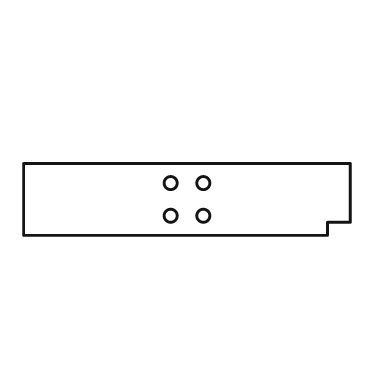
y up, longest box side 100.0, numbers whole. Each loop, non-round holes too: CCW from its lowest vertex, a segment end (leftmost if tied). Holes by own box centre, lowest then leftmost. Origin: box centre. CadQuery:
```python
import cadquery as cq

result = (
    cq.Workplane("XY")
    .moveTo(-50.0, -11.0)
    .lineTo(43.0, -11.0)
    .lineTo(43.0, -7.0)
    .lineTo(50.0, -7.0)
    .lineTo(50.0, 11.0)
    .lineTo(-50.0, 11.0)
    .close()
    .moveTo(-5.0, -5.0)
    .circle(2.0)
    .moveTo(5.0, -5.0)
    .circle(2.0)
    .moveTo(-5.0, 5.0)
    .circle(2.0)
    .moveTo(5.0, 5.0)
    .circle(2.0)
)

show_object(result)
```